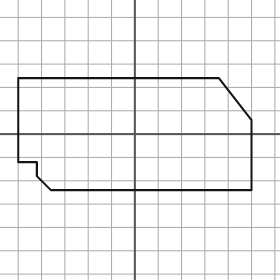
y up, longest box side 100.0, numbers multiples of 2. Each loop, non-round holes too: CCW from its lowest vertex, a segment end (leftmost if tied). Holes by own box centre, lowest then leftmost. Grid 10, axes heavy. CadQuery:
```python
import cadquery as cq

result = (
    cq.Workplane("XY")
    .moveTo(-36.0, -24.0)
    .lineTo(50.0, -24.0)
    .lineTo(50.0, 6.0)
    .lineTo(36.0, 24.0)
    .lineTo(-50.0, 24.0)
    .lineTo(-50.0, -12.0)
    .lineTo(-42.0, -12.0)
    .lineTo(-42.0, -18.0)
    .close()
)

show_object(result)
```